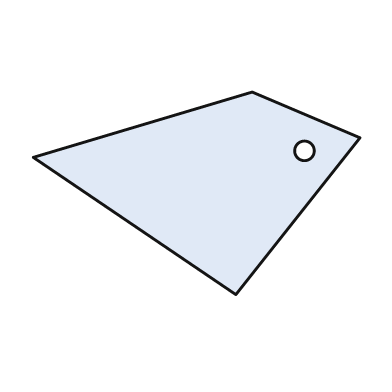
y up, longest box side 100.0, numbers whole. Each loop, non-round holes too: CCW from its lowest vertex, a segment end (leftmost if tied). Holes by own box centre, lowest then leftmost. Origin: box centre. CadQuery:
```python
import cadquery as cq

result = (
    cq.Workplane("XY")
    .moveTo(12.0, -31.0)
    .lineTo(50.0, 17.0)
    .lineTo(17.0, 31.0)
    .lineTo(-50.0, 11.0)
    .close()
    .moveTo(33.0, 13.0)
    .circle(3.0)
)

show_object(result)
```